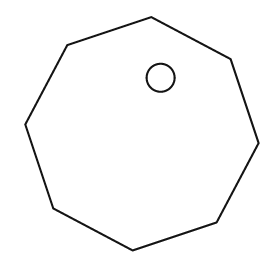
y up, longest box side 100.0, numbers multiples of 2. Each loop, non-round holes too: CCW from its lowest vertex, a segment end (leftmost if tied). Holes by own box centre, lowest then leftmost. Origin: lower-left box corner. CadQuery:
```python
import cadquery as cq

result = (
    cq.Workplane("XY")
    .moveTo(46.0, 0.0)
    .lineTo(82.0, 12.0)
    .lineTo(100.0, 46.0)
    .lineTo(88.0, 82.0)
    .lineTo(54.0, 100.0)
    .lineTo(18.0, 88.0)
    .lineTo(0.0, 54.0)
    .lineTo(12.0, 18.0)
    .close()
    .moveTo(58.0, 74.0)
    .circle(6.0)
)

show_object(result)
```